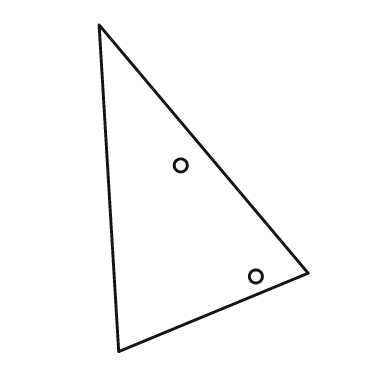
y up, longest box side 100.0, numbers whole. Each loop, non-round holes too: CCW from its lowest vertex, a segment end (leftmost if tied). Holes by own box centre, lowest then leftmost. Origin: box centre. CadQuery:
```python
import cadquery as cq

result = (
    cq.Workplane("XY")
    .moveTo(-26.0, -50.0)
    .lineTo(32.0, -26.0)
    .lineTo(-32.0, 50.0)
    .close()
    .moveTo(16.0, -27.0)
    .circle(2.0)
    .moveTo(-7.0, 7.0)
    .circle(2.0)
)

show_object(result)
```